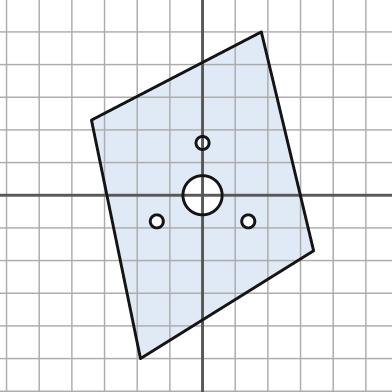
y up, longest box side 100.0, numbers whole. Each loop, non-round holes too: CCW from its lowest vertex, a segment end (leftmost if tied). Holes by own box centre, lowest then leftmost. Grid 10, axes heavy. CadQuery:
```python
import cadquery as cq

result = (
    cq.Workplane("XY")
    .moveTo(-19.0, -50.0)
    .lineTo(34.0, -17.0)
    .lineTo(18.0, 50.0)
    .lineTo(-34.0, 23.0)
    .close()
    .moveTo(-14.0, -8.0)
    .circle(2.0)
    .moveTo(14.0, -8.0)
    .circle(2.0)
    .moveTo(0.0, 0.0)
    .circle(6.0)
    .moveTo(0.0, 16.0)
    .circle(2.0)
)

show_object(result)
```